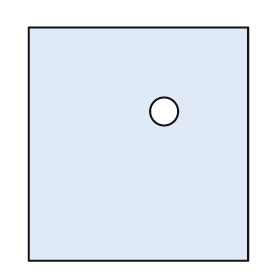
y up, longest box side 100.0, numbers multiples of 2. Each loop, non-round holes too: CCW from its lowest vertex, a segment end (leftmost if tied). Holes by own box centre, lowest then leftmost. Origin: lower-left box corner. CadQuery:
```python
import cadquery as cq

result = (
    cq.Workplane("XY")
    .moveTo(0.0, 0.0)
    .lineTo(94.0, 0.0)
    .lineTo(94.0, 100.0)
    .lineTo(0.0, 100.0)
    .close()
    .moveTo(58.0, 64.0)
    .circle(6.0)
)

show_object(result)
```